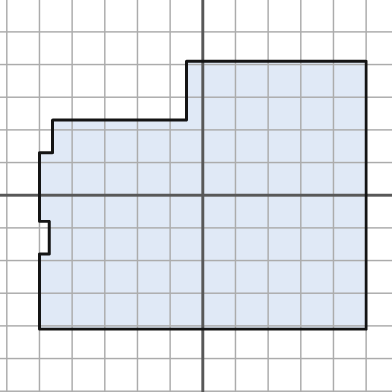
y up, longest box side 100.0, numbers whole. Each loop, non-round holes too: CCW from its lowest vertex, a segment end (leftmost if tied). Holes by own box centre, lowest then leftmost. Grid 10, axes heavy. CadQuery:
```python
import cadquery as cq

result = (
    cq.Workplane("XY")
    .moveTo(-50.0, -41.0)
    .lineTo(50.0, -41.0)
    .lineTo(50.0, 41.0)
    .lineTo(-5.0, 41.0)
    .lineTo(-5.0, 23.0)
    .lineTo(-46.0, 23.0)
    .lineTo(-46.0, 13.0)
    .lineTo(-50.0, 13.0)
    .lineTo(-50.0, -8.0)
    .lineTo(-47.0, -8.0)
    .lineTo(-47.0, -18.0)
    .lineTo(-50.0, -18.0)
    .close()
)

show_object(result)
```